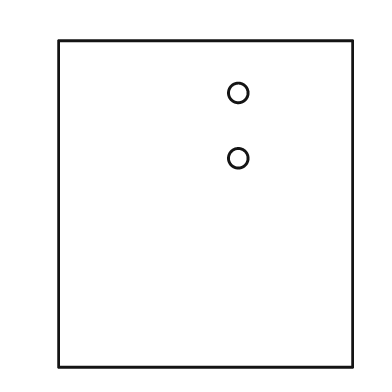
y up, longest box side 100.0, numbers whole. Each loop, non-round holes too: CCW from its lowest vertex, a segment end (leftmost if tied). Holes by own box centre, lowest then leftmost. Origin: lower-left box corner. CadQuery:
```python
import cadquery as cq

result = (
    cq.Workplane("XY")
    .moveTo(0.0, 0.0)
    .lineTo(90.0, 0.0)
    .lineTo(90.0, 100.0)
    .lineTo(0.0, 100.0)
    .close()
    .moveTo(55.0, 64.0)
    .circle(3.0)
    .moveTo(55.0, 84.0)
    .circle(3.0)
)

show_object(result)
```